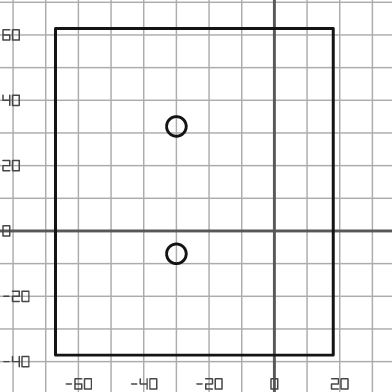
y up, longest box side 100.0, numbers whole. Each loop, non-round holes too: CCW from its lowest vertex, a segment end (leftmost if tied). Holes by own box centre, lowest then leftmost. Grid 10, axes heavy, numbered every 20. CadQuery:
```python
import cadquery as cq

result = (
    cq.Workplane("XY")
    .moveTo(-67.0, -38.0)
    .lineTo(18.0, -38.0)
    .lineTo(18.0, 62.0)
    .lineTo(-67.0, 62.0)
    .close()
    .moveTo(-30.0, -7.0)
    .circle(3.0)
    .moveTo(-30.0, 32.0)
    .circle(3.0)
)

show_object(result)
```